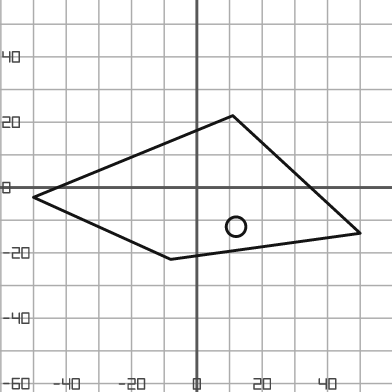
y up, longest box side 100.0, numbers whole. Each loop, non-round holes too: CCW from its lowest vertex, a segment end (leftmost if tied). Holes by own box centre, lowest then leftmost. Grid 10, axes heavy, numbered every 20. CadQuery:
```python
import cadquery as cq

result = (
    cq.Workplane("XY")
    .moveTo(-8.0, -22.0)
    .lineTo(50.0, -14.0)
    .lineTo(11.0, 22.0)
    .lineTo(-50.0, -3.0)
    .close()
    .moveTo(12.0, -12.0)
    .circle(3.0)
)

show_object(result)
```